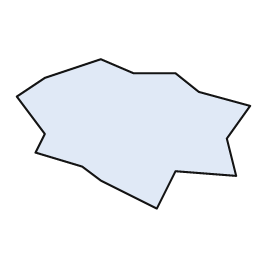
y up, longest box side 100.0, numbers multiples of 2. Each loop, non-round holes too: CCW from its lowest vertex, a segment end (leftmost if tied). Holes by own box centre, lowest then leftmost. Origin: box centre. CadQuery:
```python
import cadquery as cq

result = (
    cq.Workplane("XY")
    .moveTo(10.0, -32.0)
    .lineTo(18.0, -16.0)
    .lineTo(44.0, -18.0)
    .lineTo(40.0, -2.0)
    .lineTo(50.0, 12.0)
    .lineTo(28.0, 18.0)
    .lineTo(18.0, 26.0)
    .lineTo(0.0, 26.0)
    .lineTo(-14.0, 32.0)
    .lineTo(-38.0, 24.0)
    .lineTo(-50.0, 16.0)
    .lineTo(-38.0, 0.0)
    .lineTo(-42.0, -8.0)
    .lineTo(-22.0, -14.0)
    .lineTo(-14.0, -20.0)
    .close()
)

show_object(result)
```